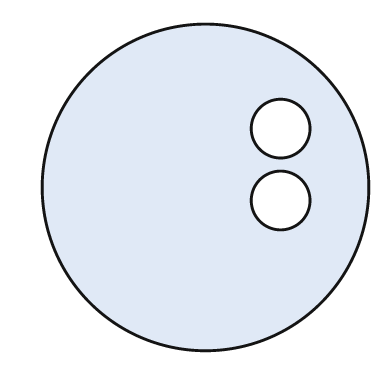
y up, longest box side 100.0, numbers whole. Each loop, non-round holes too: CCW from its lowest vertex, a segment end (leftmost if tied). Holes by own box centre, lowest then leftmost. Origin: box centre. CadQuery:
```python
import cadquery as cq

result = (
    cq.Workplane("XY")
    .moveTo(0.0, 0.0)
    .circle(50.0)
    .moveTo(23.0, -4.0)
    .circle(9.0)
    .moveTo(23.0, 18.0)
    .circle(9.0)
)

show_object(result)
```